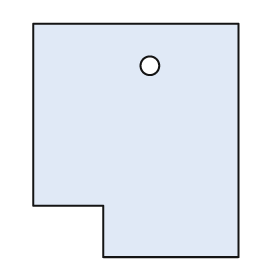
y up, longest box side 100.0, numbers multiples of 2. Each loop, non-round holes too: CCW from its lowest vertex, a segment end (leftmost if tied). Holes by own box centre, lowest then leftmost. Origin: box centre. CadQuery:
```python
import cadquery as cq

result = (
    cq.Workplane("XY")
    .moveTo(-14.0, -50.0)
    .lineTo(44.0, -50.0)
    .lineTo(44.0, 50.0)
    .lineTo(-44.0, 50.0)
    .lineTo(-44.0, -28.0)
    .lineTo(-14.0, -28.0)
    .close()
    .moveTo(6.0, 32.0)
    .circle(4.0)
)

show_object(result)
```